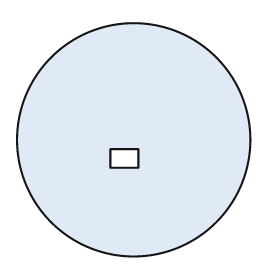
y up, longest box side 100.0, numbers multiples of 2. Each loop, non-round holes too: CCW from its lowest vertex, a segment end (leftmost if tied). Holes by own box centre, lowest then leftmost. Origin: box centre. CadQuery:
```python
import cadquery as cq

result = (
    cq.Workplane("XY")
    .moveTo(0.0, 0.0)
    .circle(50.0)
    .moveTo(-10.0, -12.0)
    .lineTo(2.0, -12.0)
    .lineTo(2.0, -4.0)
    .lineTo(-10.0, -4.0)
    .close()
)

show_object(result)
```